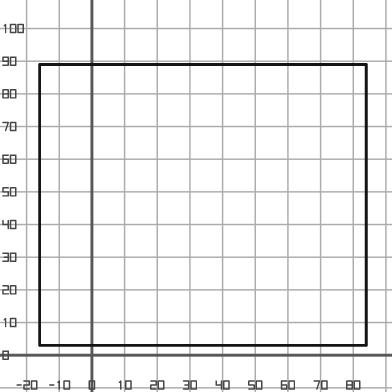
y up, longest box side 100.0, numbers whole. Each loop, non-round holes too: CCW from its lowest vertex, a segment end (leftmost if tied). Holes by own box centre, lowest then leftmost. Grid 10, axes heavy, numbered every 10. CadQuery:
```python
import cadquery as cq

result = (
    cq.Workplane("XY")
    .moveTo(-16.0, 3.0)
    .lineTo(84.0, 3.0)
    .lineTo(84.0, 89.0)
    .lineTo(-16.0, 89.0)
    .close()
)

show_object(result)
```